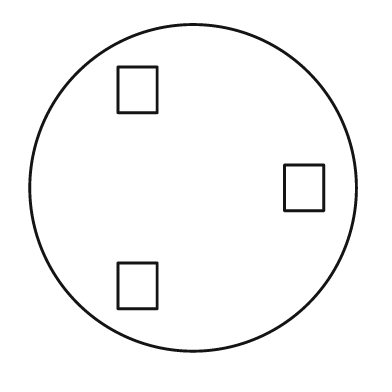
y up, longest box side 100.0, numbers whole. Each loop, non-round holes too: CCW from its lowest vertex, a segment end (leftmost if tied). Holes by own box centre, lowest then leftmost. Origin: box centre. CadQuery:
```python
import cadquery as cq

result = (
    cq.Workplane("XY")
    .moveTo(0.0, 0.0)
    .circle(50.0)
    .moveTo(-23.0, -37.0)
    .lineTo(-11.0, -37.0)
    .lineTo(-11.0, -23.0)
    .lineTo(-23.0, -23.0)
    .close()
    .moveTo(28.0, -7.0)
    .lineTo(40.0, -7.0)
    .lineTo(40.0, 7.0)
    .lineTo(28.0, 7.0)
    .close()
    .moveTo(-23.0, 23.0)
    .lineTo(-11.0, 23.0)
    .lineTo(-11.0, 37.0)
    .lineTo(-23.0, 37.0)
    .close()
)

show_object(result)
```